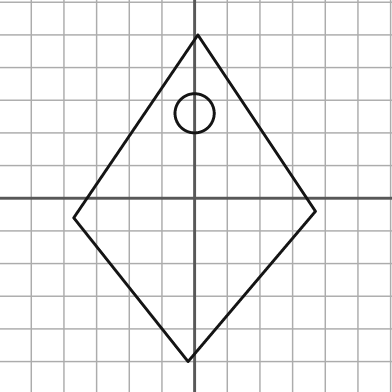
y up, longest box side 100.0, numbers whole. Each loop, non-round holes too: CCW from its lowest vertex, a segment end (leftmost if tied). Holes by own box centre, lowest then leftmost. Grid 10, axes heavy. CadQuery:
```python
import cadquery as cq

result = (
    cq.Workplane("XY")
    .moveTo(-2.0, -50.0)
    .lineTo(37.0, -4.0)
    .lineTo(1.0, 50.0)
    .lineTo(-37.0, -6.0)
    .close()
    .moveTo(0.0, 26.0)
    .circle(6.0)
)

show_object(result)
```